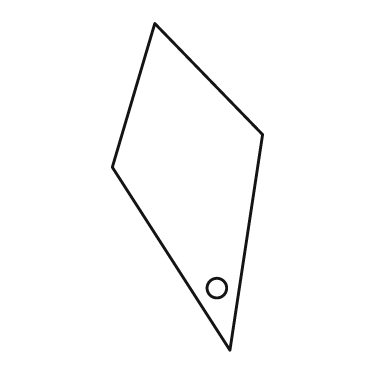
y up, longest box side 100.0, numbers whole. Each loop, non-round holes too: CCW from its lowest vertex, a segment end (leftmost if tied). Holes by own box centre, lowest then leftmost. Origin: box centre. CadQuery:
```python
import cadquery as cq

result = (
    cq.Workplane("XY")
    .moveTo(13.0, -50.0)
    .lineTo(23.0, 16.0)
    .lineTo(-10.0, 50.0)
    .lineTo(-23.0, 6.0)
    .close()
    .moveTo(9.0, -31.0)
    .circle(3.0)
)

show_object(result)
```